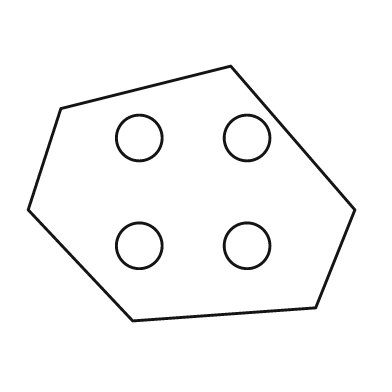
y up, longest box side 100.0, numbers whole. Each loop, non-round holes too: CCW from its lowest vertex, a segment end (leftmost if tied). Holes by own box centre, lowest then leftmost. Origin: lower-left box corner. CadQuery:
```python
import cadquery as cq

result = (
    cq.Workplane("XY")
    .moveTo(32.0, 0.0)
    .lineTo(88.0, 4.0)
    .lineTo(100.0, 34.0)
    .lineTo(62.0, 78.0)
    .lineTo(10.0, 65.0)
    .lineTo(0.0, 34.0)
    .close()
    .moveTo(34.0, 23.0)
    .circle(7.0)
    .moveTo(67.0, 23.0)
    .circle(7.0)
    .moveTo(34.0, 56.0)
    .circle(7.0)
    .moveTo(67.0, 56.0)
    .circle(7.0)
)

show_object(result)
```